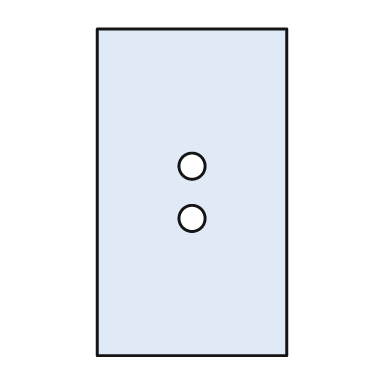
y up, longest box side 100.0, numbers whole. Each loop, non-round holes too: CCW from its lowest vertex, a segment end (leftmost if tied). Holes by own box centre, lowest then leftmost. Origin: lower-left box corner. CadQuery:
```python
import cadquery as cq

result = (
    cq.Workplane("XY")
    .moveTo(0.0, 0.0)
    .lineTo(58.0, 0.0)
    .lineTo(58.0, 100.0)
    .lineTo(0.0, 100.0)
    .close()
    .moveTo(29.0, 42.0)
    .circle(4.0)
    .moveTo(29.0, 58.0)
    .circle(4.0)
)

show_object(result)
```